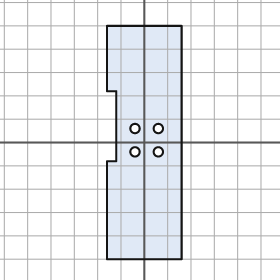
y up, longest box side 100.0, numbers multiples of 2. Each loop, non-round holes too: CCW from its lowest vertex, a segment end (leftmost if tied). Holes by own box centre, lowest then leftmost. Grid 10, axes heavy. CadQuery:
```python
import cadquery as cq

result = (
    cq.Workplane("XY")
    .moveTo(-16.0, -50.0)
    .lineTo(16.0, -50.0)
    .lineTo(16.0, 50.0)
    .lineTo(-16.0, 50.0)
    .lineTo(-16.0, 22.0)
    .lineTo(-12.0, 22.0)
    .lineTo(-12.0, -8.0)
    .lineTo(-16.0, -8.0)
    .close()
    .moveTo(-4.0, -4.0)
    .circle(2.0)
    .moveTo(6.0, -4.0)
    .circle(2.0)
    .moveTo(-4.0, 6.0)
    .circle(2.0)
    .moveTo(6.0, 6.0)
    .circle(2.0)
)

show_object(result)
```